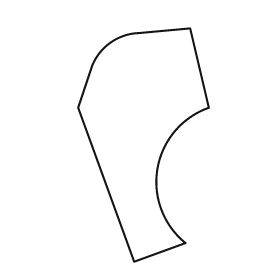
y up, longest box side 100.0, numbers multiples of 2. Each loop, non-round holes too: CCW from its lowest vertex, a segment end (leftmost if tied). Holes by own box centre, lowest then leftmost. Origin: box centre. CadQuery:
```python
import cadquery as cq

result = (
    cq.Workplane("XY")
    .moveTo(-4.0, -50.0)
    .lineTo(18.0, -42.0)
    .threePointArc((6.0, -10.0), (28.0, 16.0))
    .lineTo(20.0, 50.0)
    .lineTo(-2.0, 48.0)
    .threePointArc((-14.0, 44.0), (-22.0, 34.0))
    .lineTo(-28.0, 16.0)
    .close()
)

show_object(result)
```